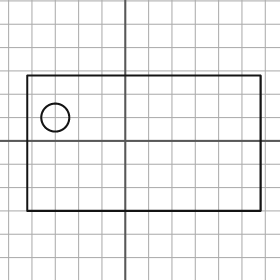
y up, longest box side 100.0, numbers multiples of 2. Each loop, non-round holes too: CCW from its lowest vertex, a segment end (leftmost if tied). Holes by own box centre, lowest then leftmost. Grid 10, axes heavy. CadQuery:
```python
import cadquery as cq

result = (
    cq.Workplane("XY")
    .moveTo(-42.0, -30.0)
    .lineTo(58.0, -30.0)
    .lineTo(58.0, 28.0)
    .lineTo(-42.0, 28.0)
    .close()
    .moveTo(-30.0, 10.0)
    .circle(6.0)
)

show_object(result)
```